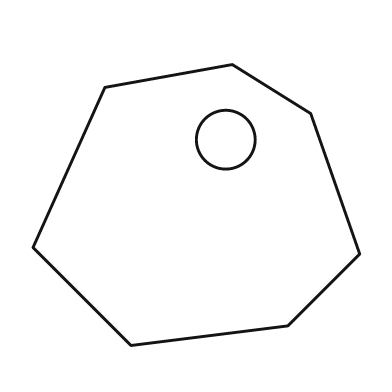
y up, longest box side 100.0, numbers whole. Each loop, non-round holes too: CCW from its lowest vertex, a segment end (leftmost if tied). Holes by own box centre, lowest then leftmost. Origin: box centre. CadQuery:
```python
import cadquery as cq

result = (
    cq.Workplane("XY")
    .moveTo(-20.0, -43.0)
    .lineTo(28.0, -37.0)
    .lineTo(50.0, -15.0)
    .lineTo(35.0, 28.0)
    .lineTo(11.0, 43.0)
    .lineTo(-28.0, 36.0)
    .lineTo(-50.0, -13.0)
    .close()
    .moveTo(9.0, 20.0)
    .circle(9.0)
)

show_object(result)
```